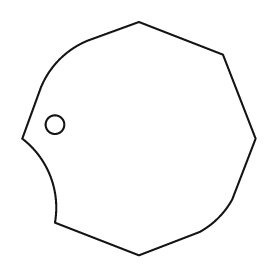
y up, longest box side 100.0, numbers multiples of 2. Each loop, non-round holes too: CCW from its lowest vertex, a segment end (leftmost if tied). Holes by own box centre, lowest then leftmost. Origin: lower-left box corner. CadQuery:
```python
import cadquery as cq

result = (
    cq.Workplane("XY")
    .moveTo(50.0, 0.0)
    .lineTo(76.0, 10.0)
    .threePointArc((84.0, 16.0), (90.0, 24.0))
    .lineTo(100.0, 50.0)
    .lineTo(86.0, 86.0)
    .lineTo(50.0, 100.0)
    .lineTo(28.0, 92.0)
    .threePointArc((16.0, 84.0), (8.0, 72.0))
    .lineTo(0.0, 50.0)
    .threePointArc((12.0, 34.0), (14.0, 14.0))
    .close()
    .moveTo(14.0, 56.0)
    .circle(4.0)
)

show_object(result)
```